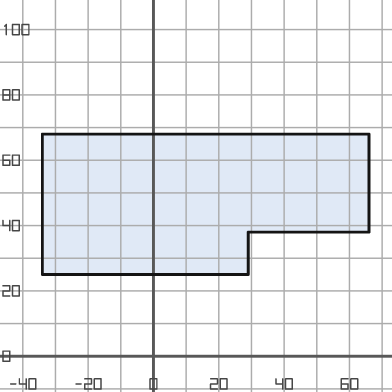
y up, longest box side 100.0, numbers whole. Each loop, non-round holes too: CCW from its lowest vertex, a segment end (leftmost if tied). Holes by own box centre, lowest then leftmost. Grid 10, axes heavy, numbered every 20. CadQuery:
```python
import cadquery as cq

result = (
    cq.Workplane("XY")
    .moveTo(-34.0, 25.0)
    .lineTo(29.0, 25.0)
    .lineTo(29.0, 38.0)
    .lineTo(66.0, 38.0)
    .lineTo(66.0, 68.0)
    .lineTo(-34.0, 68.0)
    .close()
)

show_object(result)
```